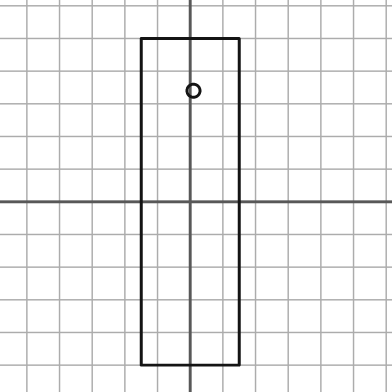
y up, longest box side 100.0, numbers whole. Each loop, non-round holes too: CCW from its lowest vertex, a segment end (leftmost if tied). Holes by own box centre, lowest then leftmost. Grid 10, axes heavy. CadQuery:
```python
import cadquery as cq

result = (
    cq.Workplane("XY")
    .moveTo(-15.0, -50.0)
    .lineTo(15.0, -50.0)
    .lineTo(15.0, 50.0)
    .lineTo(-15.0, 50.0)
    .close()
    .moveTo(1.0, 34.0)
    .circle(2.0)
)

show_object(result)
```